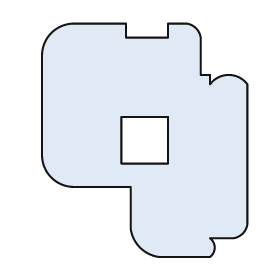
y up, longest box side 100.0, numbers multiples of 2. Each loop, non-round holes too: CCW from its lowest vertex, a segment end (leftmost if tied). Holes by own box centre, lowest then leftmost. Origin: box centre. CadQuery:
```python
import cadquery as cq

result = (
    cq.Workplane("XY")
    .moveTo(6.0, -50.0)
    .lineTo(28.0, -50.0)
    .threePointArc((30.0, -46.0), (28.0, -42.0))
    .lineTo(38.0, -42.0)
    .threePointArc((42.0, -40.0), (44.0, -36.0))
    .lineTo(44.0, 24.0)
    .threePointArc((36.0, 28.0), (28.0, 24.0))
    .lineTo(28.0, 28.0)
    .lineTo(24.0, 28.0)
    .lineTo(24.0, 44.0)
    .threePointArc((22.0, 48.0), (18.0, 50.0))
    .lineTo(10.0, 50.0)
    .lineTo(10.0, 44.0)
    .lineTo(-8.0, 44.0)
    .lineTo(-8.0, 50.0)
    .lineTo(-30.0, 50.0)
    .threePointArc((-40.0, 46.0), (-44.0, 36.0))
    .lineTo(-44.0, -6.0)
    .threePointArc((-40.0, -16.0), (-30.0, -20.0))
    .lineTo(-6.0, -20.0)
    .lineTo(-6.0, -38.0)
    .threePointArc((-2.0, -46.0), (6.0, -50.0))
    .close()
    .moveTo(-10.0, -10.0)
    .lineTo(10.0, -10.0)
    .lineTo(10.0, 10.0)
    .lineTo(-10.0, 10.0)
    .close()
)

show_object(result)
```